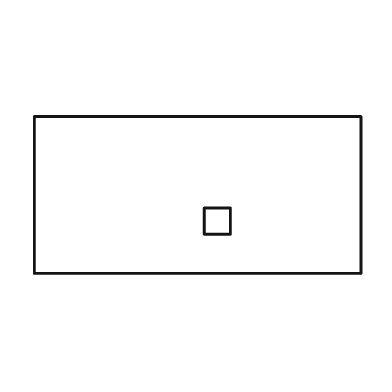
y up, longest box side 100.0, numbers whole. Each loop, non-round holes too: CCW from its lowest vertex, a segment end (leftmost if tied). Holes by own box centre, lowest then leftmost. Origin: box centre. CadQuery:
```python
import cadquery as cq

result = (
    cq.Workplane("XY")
    .moveTo(-50.0, -24.0)
    .lineTo(50.0, -24.0)
    .lineTo(50.0, 24.0)
    .lineTo(-50.0, 24.0)
    .close()
    .moveTo(2.0, -12.0)
    .lineTo(10.0, -12.0)
    .lineTo(10.0, -4.0)
    .lineTo(2.0, -4.0)
    .close()
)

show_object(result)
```